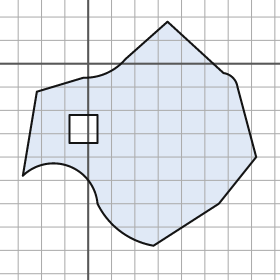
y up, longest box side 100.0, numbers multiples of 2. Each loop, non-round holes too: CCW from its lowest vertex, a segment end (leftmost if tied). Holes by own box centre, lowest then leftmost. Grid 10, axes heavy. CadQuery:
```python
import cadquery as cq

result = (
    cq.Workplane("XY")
    .moveTo(28.0, -78.0)
    .lineTo(56.0, -60.0)
    .lineTo(72.0, -40.0)
    .lineTo(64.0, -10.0)
    .threePointArc((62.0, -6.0), (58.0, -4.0))
    .lineTo(34.0, 18.0)
    .lineTo(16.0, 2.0)
    .threePointArc((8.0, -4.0), (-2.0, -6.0))
    .lineTo(-22.0, -12.0)
    .lineTo(-28.0, -48.0)
    .threePointArc((-8.0, -44.0), (4.0, -60.0))
    .threePointArc((14.0, -72.0), (28.0, -78.0))
    .close()
    .moveTo(-8.0, -34.0)
    .lineTo(4.0, -34.0)
    .lineTo(4.0, -22.0)
    .lineTo(-8.0, -22.0)
    .close()
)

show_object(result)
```